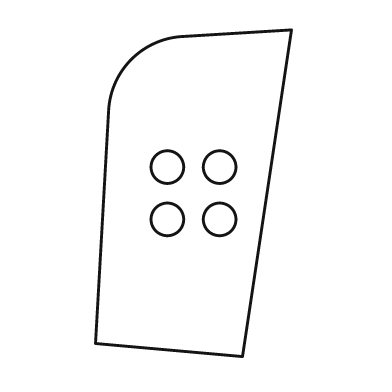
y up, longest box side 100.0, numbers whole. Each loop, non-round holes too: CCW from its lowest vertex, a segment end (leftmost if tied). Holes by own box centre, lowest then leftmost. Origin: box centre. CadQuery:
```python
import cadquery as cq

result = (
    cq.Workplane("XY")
    .moveTo(15.0, -50.0)
    .lineTo(30.0, 50.0)
    .lineTo(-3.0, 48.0)
    .threePointArc((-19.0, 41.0), (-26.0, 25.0))
    .lineTo(-30.0, -46.0)
    .close()
    .moveTo(-8.0, -8.0)
    .circle(5.0)
    .moveTo(8.0, -8.0)
    .circle(5.0)
    .moveTo(-8.0, 8.0)
    .circle(5.0)
    .moveTo(8.0, 8.0)
    .circle(5.0)
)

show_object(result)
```